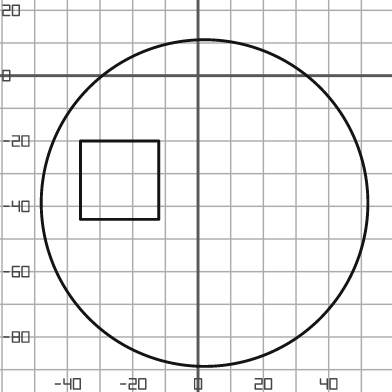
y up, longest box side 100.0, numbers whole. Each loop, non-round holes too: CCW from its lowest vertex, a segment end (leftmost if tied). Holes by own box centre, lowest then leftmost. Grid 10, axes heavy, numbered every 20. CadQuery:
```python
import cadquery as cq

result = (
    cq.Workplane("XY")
    .moveTo(2.0, -39.0)
    .circle(50.0)
    .moveTo(-36.0, -44.0)
    .lineTo(-12.0, -44.0)
    .lineTo(-12.0, -20.0)
    .lineTo(-36.0, -20.0)
    .close()
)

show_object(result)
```